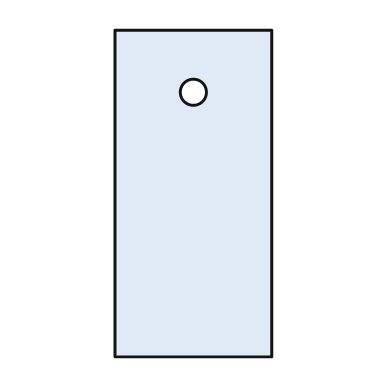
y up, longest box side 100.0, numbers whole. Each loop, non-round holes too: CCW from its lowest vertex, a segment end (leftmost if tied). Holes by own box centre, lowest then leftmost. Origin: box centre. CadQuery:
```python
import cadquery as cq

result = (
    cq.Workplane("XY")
    .moveTo(-24.0, -50.0)
    .lineTo(24.0, -50.0)
    .lineTo(24.0, 50.0)
    .lineTo(-24.0, 50.0)
    .close()
    .moveTo(0.0, 31.0)
    .circle(4.0)
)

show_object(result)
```